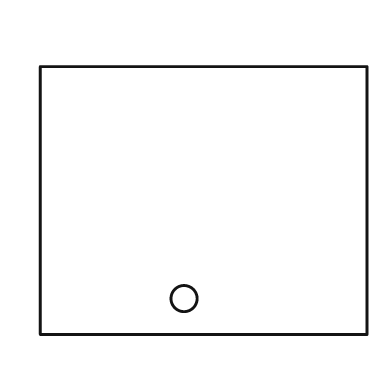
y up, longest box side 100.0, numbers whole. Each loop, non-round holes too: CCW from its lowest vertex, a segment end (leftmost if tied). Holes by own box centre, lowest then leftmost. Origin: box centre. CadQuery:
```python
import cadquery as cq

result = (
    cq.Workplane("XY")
    .moveTo(-50.0, -41.0)
    .lineTo(50.0, -41.0)
    .lineTo(50.0, 41.0)
    .lineTo(-50.0, 41.0)
    .close()
    .moveTo(-6.0, -30.0)
    .circle(4.0)
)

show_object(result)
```